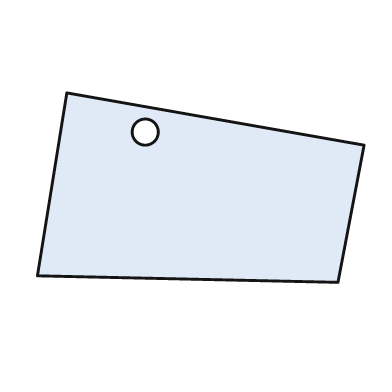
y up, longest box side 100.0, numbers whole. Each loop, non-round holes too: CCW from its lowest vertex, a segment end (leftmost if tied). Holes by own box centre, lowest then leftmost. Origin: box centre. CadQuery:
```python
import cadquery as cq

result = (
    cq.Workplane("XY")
    .moveTo(42.0, -29.0)
    .lineTo(50.0, 13.0)
    .lineTo(-41.0, 29.0)
    .lineTo(-50.0, -27.0)
    .close()
    .moveTo(-17.0, 17.0)
    .circle(4.0)
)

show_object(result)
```